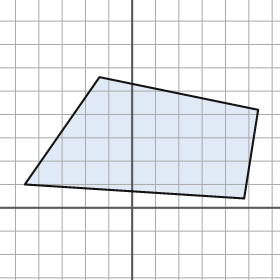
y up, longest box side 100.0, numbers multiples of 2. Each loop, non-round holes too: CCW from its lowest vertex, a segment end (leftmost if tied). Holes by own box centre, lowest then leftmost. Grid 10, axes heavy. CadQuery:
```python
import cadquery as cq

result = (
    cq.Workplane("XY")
    .moveTo(48.0, 4.0)
    .lineTo(54.0, 42.0)
    .lineTo(-14.0, 56.0)
    .lineTo(-46.0, 10.0)
    .close()
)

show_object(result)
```